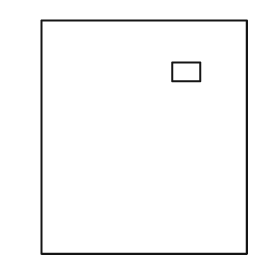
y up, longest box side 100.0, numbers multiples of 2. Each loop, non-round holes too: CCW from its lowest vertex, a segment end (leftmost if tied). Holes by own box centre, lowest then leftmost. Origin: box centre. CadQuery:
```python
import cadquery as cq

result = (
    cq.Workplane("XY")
    .moveTo(-44.0, -50.0)
    .lineTo(44.0, -50.0)
    .lineTo(44.0, 50.0)
    .lineTo(-44.0, 50.0)
    .close()
    .moveTo(12.0, 24.0)
    .lineTo(24.0, 24.0)
    .lineTo(24.0, 32.0)
    .lineTo(12.0, 32.0)
    .close()
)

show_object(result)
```